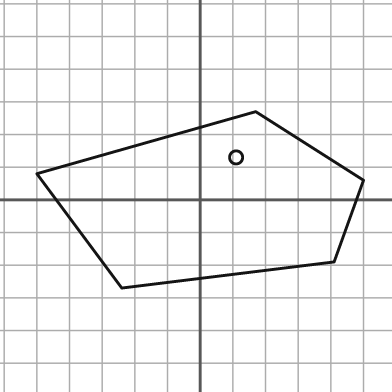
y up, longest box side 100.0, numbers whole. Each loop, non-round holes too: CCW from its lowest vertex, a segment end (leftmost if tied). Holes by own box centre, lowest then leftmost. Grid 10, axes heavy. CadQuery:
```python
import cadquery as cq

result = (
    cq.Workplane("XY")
    .moveTo(-24.0, -27.0)
    .lineTo(41.0, -19.0)
    .lineTo(50.0, 6.0)
    .lineTo(17.0, 27.0)
    .lineTo(-50.0, 8.0)
    .close()
    .moveTo(11.0, 13.0)
    .circle(2.0)
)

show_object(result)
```